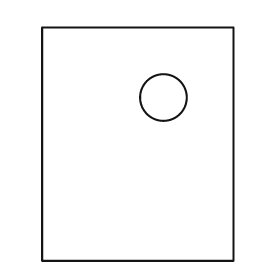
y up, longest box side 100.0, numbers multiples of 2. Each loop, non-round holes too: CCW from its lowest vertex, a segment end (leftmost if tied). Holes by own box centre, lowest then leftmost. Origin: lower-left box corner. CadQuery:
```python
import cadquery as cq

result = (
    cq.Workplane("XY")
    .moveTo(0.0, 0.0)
    .lineTo(82.0, 0.0)
    .lineTo(82.0, 100.0)
    .lineTo(0.0, 100.0)
    .close()
    .moveTo(52.0, 70.0)
    .circle(10.0)
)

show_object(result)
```